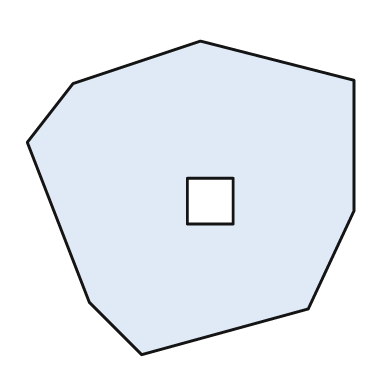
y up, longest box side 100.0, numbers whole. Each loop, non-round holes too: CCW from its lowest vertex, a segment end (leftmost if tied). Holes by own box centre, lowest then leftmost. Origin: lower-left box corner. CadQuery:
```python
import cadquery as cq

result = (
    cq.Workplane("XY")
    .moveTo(35.0, 0.0)
    .lineTo(86.0, 14.0)
    .lineTo(100.0, 44.0)
    .lineTo(100.0, 84.0)
    .lineTo(53.0, 96.0)
    .lineTo(14.0, 83.0)
    .lineTo(0.0, 65.0)
    .lineTo(19.0, 16.0)
    .close()
    .moveTo(49.0, 40.0)
    .lineTo(63.0, 40.0)
    .lineTo(63.0, 54.0)
    .lineTo(49.0, 54.0)
    .close()
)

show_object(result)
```